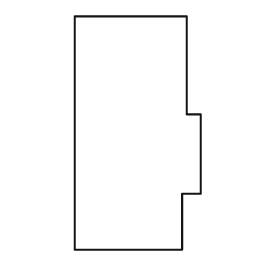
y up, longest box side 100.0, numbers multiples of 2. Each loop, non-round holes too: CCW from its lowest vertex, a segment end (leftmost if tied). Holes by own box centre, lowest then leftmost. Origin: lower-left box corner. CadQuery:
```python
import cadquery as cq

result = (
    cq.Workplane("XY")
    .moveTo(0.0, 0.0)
    .lineTo(46.0, 0.0)
    .lineTo(46.0, 24.0)
    .lineTo(54.0, 24.0)
    .lineTo(54.0, 58.0)
    .lineTo(48.0, 58.0)
    .lineTo(48.0, 100.0)
    .lineTo(0.0, 100.0)
    .close()
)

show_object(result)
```